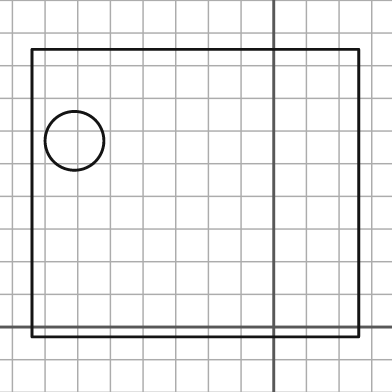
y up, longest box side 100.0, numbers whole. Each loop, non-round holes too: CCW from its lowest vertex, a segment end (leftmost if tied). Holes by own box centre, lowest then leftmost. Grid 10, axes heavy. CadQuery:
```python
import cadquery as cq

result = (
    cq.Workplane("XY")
    .moveTo(-74.0, -3.0)
    .lineTo(26.0, -3.0)
    .lineTo(26.0, 85.0)
    .lineTo(-74.0, 85.0)
    .close()
    .moveTo(-61.0, 57.0)
    .circle(9.0)
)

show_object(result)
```